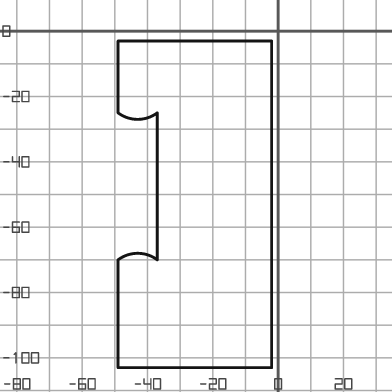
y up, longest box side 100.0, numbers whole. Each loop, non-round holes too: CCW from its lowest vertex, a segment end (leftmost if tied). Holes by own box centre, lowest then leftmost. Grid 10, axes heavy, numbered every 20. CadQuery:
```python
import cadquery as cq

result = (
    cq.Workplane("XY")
    .moveTo(-49.0, -103.0)
    .lineTo(-2.0, -103.0)
    .lineTo(-2.0, -3.0)
    .lineTo(-49.0, -3.0)
    .lineTo(-49.0, -25.0)
    .threePointArc((-43.0, -27.0), (-37.0, -25.0))
    .lineTo(-37.0, -70.0)
    .threePointArc((-43.0, -68.0), (-49.0, -70.0))
    .close()
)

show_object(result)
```